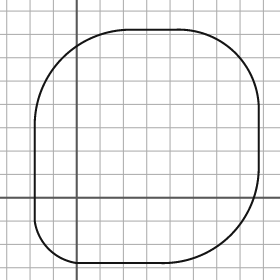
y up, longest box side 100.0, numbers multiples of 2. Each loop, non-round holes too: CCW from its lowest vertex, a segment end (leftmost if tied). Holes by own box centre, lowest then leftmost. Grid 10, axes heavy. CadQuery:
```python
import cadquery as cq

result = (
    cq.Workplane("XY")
    .moveTo(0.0, -28.0)
    .lineTo(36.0, -28.0)
    .threePointArc((66.0, -16.0), (78.0, 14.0))
    .lineTo(78.0, 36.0)
    .threePointArc((68.0, 62.0), (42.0, 72.0))
    .lineTo(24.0, 72.0)
    .threePointArc((-6.0, 60.0), (-18.0, 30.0))
    .lineTo(-18.0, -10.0)
    .threePointArc((-12.0, -22.0), (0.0, -28.0))
    .close()
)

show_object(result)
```